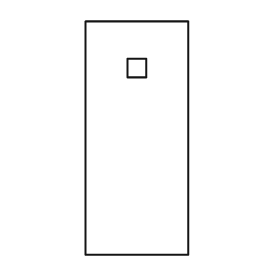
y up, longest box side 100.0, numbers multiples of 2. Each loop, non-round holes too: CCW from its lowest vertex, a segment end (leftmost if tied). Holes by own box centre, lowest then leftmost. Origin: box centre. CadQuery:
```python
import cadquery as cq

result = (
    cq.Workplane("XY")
    .moveTo(-22.0, -50.0)
    .lineTo(22.0, -50.0)
    .lineTo(22.0, 50.0)
    .lineTo(-22.0, 50.0)
    .close()
    .moveTo(-4.0, 26.0)
    .lineTo(4.0, 26.0)
    .lineTo(4.0, 34.0)
    .lineTo(-4.0, 34.0)
    .close()
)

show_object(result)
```